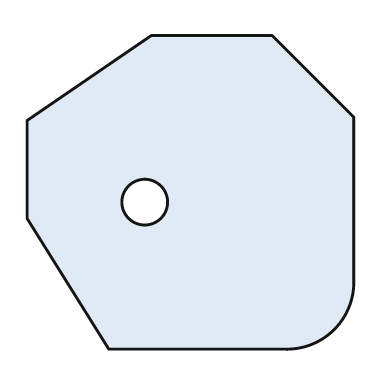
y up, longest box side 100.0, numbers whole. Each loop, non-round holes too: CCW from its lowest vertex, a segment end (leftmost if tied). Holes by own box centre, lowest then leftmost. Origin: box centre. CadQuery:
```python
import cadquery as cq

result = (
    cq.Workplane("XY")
    .moveTo(-25.0, -48.0)
    .lineTo(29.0, -48.0)
    .threePointArc((44.0, -42.0), (50.0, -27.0))
    .lineTo(50.0, 23.0)
    .lineTo(25.0, 48.0)
    .lineTo(-12.0, 48.0)
    .lineTo(-50.0, 22.0)
    .lineTo(-50.0, -8.0)
    .close()
    .moveTo(-14.0, -3.0)
    .circle(7.0)
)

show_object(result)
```